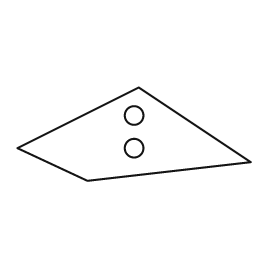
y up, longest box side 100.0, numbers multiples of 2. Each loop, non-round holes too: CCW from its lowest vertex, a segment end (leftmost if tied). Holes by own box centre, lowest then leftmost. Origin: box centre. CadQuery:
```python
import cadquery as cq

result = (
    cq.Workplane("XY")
    .moveTo(-20.0, -20.0)
    .lineTo(50.0, -12.0)
    .lineTo(2.0, 20.0)
    .lineTo(-50.0, -6.0)
    .close()
    .moveTo(0.0, -6.0)
    .circle(4.0)
    .moveTo(0.0, 8.0)
    .circle(4.0)
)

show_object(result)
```